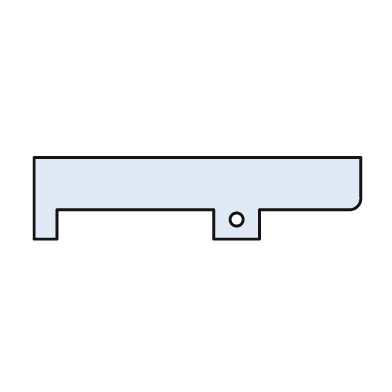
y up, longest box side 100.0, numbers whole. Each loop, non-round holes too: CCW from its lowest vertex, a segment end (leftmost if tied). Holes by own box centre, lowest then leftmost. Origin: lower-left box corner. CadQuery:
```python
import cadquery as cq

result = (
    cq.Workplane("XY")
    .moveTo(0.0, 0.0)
    .lineTo(7.0, 0.0)
    .lineTo(7.0, 9.0)
    .lineTo(55.0, 9.0)
    .lineTo(55.0, 0.0)
    .lineTo(69.0, 0.0)
    .lineTo(69.0, 9.0)
    .lineTo(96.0, 9.0)
    .threePointArc((99.0, 10.0), (100.0, 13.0))
    .lineTo(100.0, 25.0)
    .lineTo(0.0, 25.0)
    .close()
    .moveTo(62.0, 6.0)
    .circle(2.0)
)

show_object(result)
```